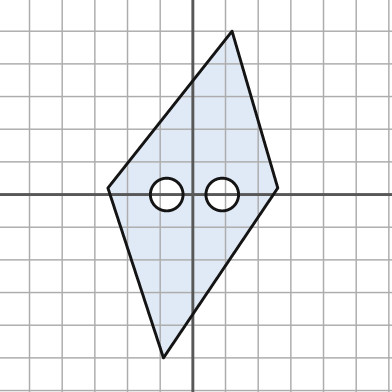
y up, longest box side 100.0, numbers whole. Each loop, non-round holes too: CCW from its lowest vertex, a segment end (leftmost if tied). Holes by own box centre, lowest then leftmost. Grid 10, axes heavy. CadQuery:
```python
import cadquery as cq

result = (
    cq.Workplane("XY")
    .moveTo(-9.0, -50.0)
    .lineTo(26.0, 2.0)
    .lineTo(12.0, 50.0)
    .lineTo(-26.0, 2.0)
    .close()
    .moveTo(-8.0, 0.0)
    .circle(5.0)
    .moveTo(9.0, 0.0)
    .circle(5.0)
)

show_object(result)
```